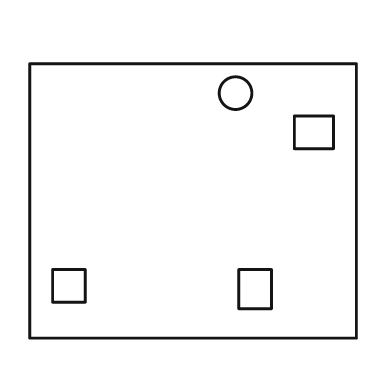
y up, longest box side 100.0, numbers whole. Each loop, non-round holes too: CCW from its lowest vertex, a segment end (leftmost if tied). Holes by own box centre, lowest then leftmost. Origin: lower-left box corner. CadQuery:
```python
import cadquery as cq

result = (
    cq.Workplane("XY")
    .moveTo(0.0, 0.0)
    .lineTo(100.0, 0.0)
    .lineTo(100.0, 84.0)
    .lineTo(0.0, 84.0)
    .close()
    .moveTo(64.0, 9.0)
    .lineTo(74.0, 9.0)
    .lineTo(74.0, 21.0)
    .lineTo(64.0, 21.0)
    .close()
    .moveTo(7.0, 11.0)
    .lineTo(17.0, 11.0)
    .lineTo(17.0, 21.0)
    .lineTo(7.0, 21.0)
    .close()
    .moveTo(81.0, 58.0)
    .lineTo(93.0, 58.0)
    .lineTo(93.0, 68.0)
    .lineTo(81.0, 68.0)
    .close()
    .moveTo(63.0, 75.0)
    .circle(5.0)
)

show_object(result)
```